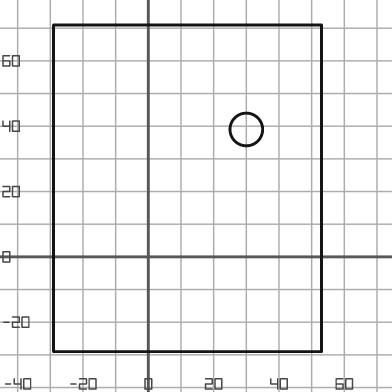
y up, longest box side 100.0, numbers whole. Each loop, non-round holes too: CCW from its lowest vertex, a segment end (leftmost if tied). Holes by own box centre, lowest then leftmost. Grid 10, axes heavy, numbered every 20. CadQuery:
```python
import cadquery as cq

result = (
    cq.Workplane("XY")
    .moveTo(-29.0, -29.0)
    .lineTo(53.0, -29.0)
    .lineTo(53.0, 71.0)
    .lineTo(-29.0, 71.0)
    .close()
    .moveTo(30.0, 39.0)
    .circle(5.0)
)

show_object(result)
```